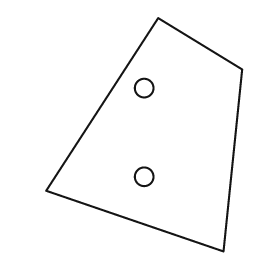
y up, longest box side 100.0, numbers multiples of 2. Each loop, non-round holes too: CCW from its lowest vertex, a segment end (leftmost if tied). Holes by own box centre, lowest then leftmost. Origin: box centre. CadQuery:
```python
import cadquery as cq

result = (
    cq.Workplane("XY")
    .moveTo(34.0, -50.0)
    .lineTo(42.0, 28.0)
    .lineTo(6.0, 50.0)
    .lineTo(-42.0, -24.0)
    .close()
    .moveTo(0.0, -18.0)
    .circle(4.0)
    .moveTo(0.0, 20.0)
    .circle(4.0)
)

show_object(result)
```